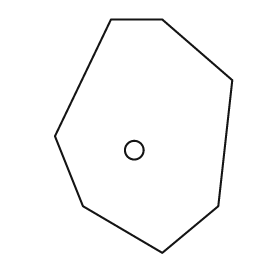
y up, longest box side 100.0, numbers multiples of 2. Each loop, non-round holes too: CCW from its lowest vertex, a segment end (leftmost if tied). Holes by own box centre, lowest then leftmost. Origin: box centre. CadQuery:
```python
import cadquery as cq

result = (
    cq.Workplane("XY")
    .moveTo(8.0, -50.0)
    .lineTo(32.0, -30.0)
    .lineTo(38.0, 24.0)
    .lineTo(8.0, 50.0)
    .lineTo(-14.0, 50.0)
    .lineTo(-38.0, 0.0)
    .lineTo(-26.0, -30.0)
    .close()
    .moveTo(-4.0, -6.0)
    .circle(4.0)
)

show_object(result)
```